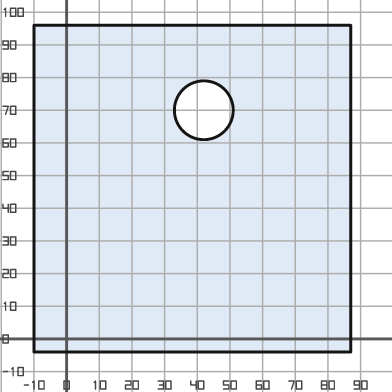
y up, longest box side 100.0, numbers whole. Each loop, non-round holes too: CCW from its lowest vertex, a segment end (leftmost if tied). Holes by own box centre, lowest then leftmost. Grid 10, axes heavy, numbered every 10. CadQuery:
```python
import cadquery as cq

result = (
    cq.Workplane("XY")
    .moveTo(-10.0, -4.0)
    .lineTo(87.0, -4.0)
    .lineTo(87.0, 96.0)
    .lineTo(-10.0, 96.0)
    .close()
    .moveTo(42.0, 70.0)
    .circle(9.0)
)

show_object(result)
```